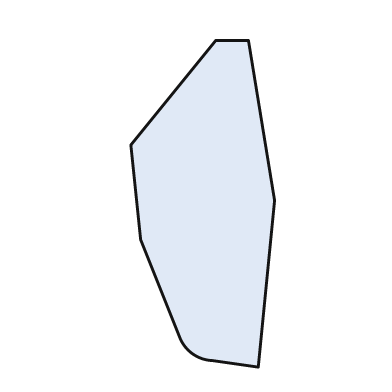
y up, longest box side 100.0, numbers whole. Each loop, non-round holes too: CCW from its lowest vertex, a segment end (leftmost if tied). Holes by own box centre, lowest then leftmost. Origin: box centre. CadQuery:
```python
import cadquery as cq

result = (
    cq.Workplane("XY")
    .moveTo(17.0, -50.0)
    .lineTo(22.0, 1.0)
    .lineTo(14.0, 50.0)
    .lineTo(4.0, 50.0)
    .lineTo(-22.0, 18.0)
    .lineTo(-19.0, -11.0)
    .lineTo(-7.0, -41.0)
    .threePointArc((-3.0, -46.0), (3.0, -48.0))
    .close()
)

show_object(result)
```